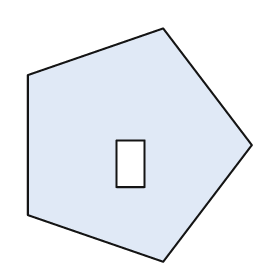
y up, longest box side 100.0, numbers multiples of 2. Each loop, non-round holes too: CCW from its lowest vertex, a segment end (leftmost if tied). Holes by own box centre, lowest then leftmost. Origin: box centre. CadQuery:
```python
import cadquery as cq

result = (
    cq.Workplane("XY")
    .moveTo(10.0, -50.0)
    .lineTo(48.0, 0.0)
    .lineTo(10.0, 50.0)
    .lineTo(-48.0, 30.0)
    .lineTo(-48.0, -30.0)
    .close()
    .moveTo(-10.0, -18.0)
    .lineTo(2.0, -18.0)
    .lineTo(2.0, 2.0)
    .lineTo(-10.0, 2.0)
    .close()
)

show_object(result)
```